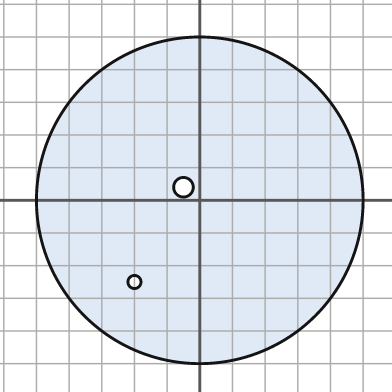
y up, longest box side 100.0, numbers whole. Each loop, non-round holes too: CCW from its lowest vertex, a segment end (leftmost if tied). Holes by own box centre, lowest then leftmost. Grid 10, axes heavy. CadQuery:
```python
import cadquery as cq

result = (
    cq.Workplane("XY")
    .moveTo(0.0, 0.0)
    .circle(50.0)
    .moveTo(-20.0, -25.0)
    .circle(2.0)
    .moveTo(-5.0, 4.0)
    .circle(3.0)
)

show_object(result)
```